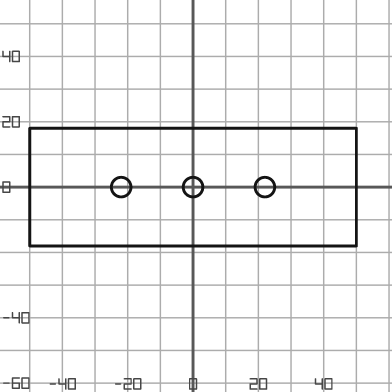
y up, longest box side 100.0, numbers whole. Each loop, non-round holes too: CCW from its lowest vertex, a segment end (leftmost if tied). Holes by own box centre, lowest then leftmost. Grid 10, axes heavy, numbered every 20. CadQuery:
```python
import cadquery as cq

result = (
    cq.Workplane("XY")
    .moveTo(-50.0, -18.0)
    .lineTo(50.0, -18.0)
    .lineTo(50.0, 18.0)
    .lineTo(-50.0, 18.0)
    .close()
    .moveTo(-22.0, 0.0)
    .circle(3.0)
    .moveTo(0.0, 0.0)
    .circle(3.0)
    .moveTo(22.0, 0.0)
    .circle(3.0)
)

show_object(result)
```